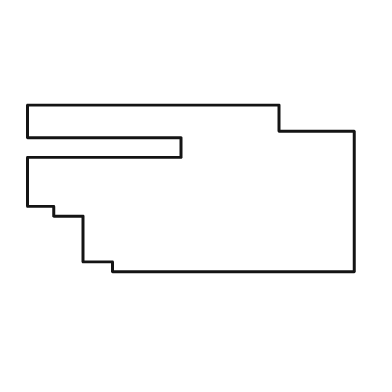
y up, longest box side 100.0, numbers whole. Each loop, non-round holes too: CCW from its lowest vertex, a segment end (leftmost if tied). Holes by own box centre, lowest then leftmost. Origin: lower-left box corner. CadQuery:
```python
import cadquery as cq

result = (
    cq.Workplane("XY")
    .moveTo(26.0, 0.0)
    .lineTo(100.0, 0.0)
    .lineTo(100.0, 43.0)
    .lineTo(77.0, 43.0)
    .lineTo(77.0, 51.0)
    .lineTo(0.0, 51.0)
    .lineTo(0.0, 41.0)
    .lineTo(47.0, 41.0)
    .lineTo(47.0, 35.0)
    .lineTo(0.0, 35.0)
    .lineTo(0.0, 20.0)
    .lineTo(8.0, 20.0)
    .lineTo(8.0, 17.0)
    .lineTo(17.0, 17.0)
    .lineTo(17.0, 3.0)
    .lineTo(26.0, 3.0)
    .close()
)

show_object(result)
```